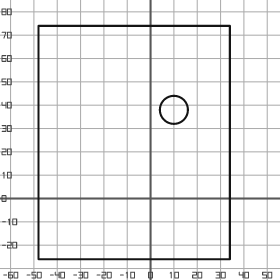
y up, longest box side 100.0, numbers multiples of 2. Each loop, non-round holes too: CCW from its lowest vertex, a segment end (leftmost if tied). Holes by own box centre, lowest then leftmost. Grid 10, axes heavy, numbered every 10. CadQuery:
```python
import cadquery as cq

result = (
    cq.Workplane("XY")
    .moveTo(-48.0, -26.0)
    .lineTo(34.0, -26.0)
    .lineTo(34.0, 74.0)
    .lineTo(-48.0, 74.0)
    .close()
    .moveTo(10.0, 38.0)
    .circle(6.0)
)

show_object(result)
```